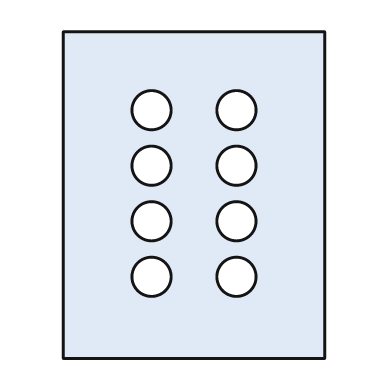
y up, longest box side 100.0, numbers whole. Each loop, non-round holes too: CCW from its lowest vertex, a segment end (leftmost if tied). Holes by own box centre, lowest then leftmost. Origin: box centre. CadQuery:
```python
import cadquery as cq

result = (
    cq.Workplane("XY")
    .moveTo(-40.0, -50.0)
    .lineTo(40.0, -50.0)
    .lineTo(40.0, 50.0)
    .lineTo(-40.0, 50.0)
    .close()
    .moveTo(-13.0, -25.0)
    .circle(6.0)
    .moveTo(13.0, -25.0)
    .circle(6.0)
    .moveTo(-13.0, -8.0)
    .circle(6.0)
    .moveTo(13.0, -8.0)
    .circle(6.0)
    .moveTo(-13.0, 9.0)
    .circle(6.0)
    .moveTo(13.0, 9.0)
    .circle(6.0)
    .moveTo(-13.0, 26.0)
    .circle(6.0)
    .moveTo(13.0, 26.0)
    .circle(6.0)
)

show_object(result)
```